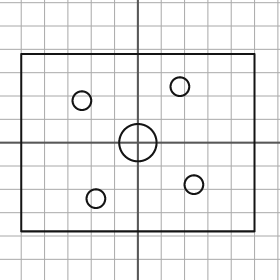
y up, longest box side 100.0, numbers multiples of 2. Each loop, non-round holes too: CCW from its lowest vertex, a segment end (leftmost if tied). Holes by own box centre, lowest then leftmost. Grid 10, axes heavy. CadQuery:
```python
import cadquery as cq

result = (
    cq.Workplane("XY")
    .moveTo(-50.0, -38.0)
    .lineTo(50.0, -38.0)
    .lineTo(50.0, 38.0)
    .lineTo(-50.0, 38.0)
    .close()
    .moveTo(-18.0, -24.0)
    .circle(4.0)
    .moveTo(24.0, -18.0)
    .circle(4.0)
    .moveTo(0.0, 0.0)
    .circle(8.0)
    .moveTo(-24.0, 18.0)
    .circle(4.0)
    .moveTo(18.0, 24.0)
    .circle(4.0)
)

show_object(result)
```